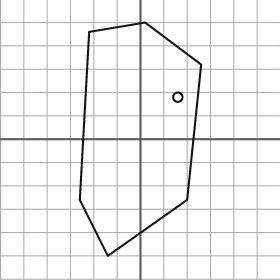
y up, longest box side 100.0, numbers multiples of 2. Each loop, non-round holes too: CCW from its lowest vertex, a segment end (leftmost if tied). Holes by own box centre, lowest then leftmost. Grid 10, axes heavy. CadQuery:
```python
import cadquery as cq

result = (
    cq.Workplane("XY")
    .moveTo(-14.0, -50.0)
    .lineTo(20.0, -26.0)
    .lineTo(26.0, 32.0)
    .lineTo(2.0, 50.0)
    .lineTo(-22.0, 46.0)
    .lineTo(-26.0, -26.0)
    .close()
    .moveTo(16.0, 18.0)
    .circle(2.0)
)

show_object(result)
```